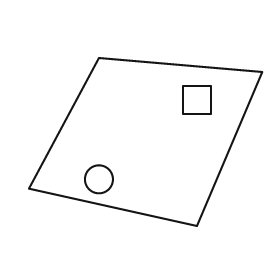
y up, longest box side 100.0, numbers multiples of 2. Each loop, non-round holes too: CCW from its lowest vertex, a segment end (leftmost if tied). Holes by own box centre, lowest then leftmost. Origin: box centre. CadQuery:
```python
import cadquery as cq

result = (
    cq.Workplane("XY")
    .moveTo(22.0, -36.0)
    .lineTo(50.0, 30.0)
    .lineTo(-20.0, 36.0)
    .lineTo(-50.0, -20.0)
    .close()
    .moveTo(-20.0, -16.0)
    .circle(6.0)
    .moveTo(16.0, 12.0)
    .lineTo(28.0, 12.0)
    .lineTo(28.0, 24.0)
    .lineTo(16.0, 24.0)
    .close()
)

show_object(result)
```